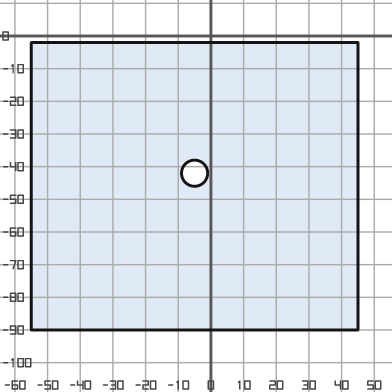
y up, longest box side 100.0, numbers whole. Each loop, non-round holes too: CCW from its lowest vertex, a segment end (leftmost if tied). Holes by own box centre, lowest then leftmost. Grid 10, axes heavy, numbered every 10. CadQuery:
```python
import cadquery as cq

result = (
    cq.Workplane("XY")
    .moveTo(-55.0, -90.0)
    .lineTo(45.0, -90.0)
    .lineTo(45.0, -2.0)
    .lineTo(-55.0, -2.0)
    .close()
    .moveTo(-5.0, -42.0)
    .circle(4.0)
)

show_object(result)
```